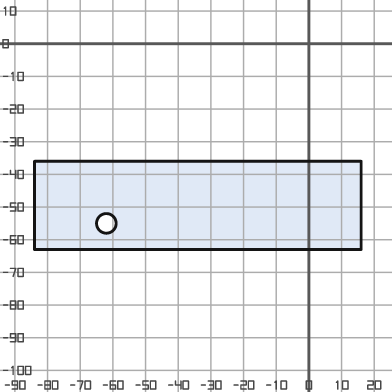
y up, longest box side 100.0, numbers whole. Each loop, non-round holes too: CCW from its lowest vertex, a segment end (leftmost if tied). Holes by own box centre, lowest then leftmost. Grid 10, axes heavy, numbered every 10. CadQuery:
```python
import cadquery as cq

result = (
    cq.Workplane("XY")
    .moveTo(-84.0, -63.0)
    .lineTo(16.0, -63.0)
    .lineTo(16.0, -36.0)
    .lineTo(-84.0, -36.0)
    .close()
    .moveTo(-62.0, -55.0)
    .circle(3.0)
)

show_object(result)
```